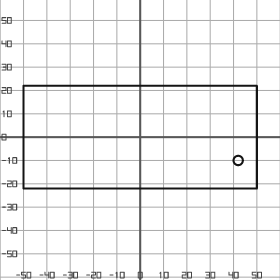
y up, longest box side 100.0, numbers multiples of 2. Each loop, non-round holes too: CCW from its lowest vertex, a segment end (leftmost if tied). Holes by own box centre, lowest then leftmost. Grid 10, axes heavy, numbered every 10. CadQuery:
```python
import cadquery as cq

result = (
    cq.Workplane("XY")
    .moveTo(-50.0, -22.0)
    .lineTo(50.0, -22.0)
    .lineTo(50.0, 22.0)
    .lineTo(-50.0, 22.0)
    .close()
    .moveTo(42.0, -10.0)
    .circle(2.0)
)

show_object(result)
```